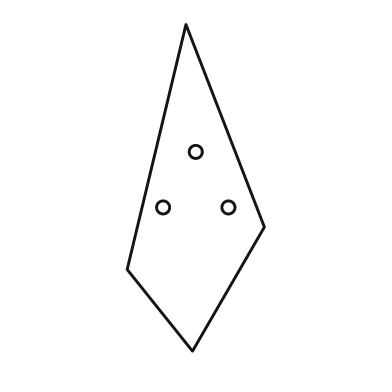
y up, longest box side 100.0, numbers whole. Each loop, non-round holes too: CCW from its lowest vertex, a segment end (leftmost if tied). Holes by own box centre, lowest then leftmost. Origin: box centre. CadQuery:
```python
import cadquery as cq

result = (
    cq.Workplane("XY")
    .moveTo(-1.0, -50.0)
    .lineTo(21.0, -12.0)
    .lineTo(-3.0, 50.0)
    .lineTo(-21.0, -25.0)
    .close()
    .moveTo(-10.0, -6.0)
    .circle(2.0)
    .moveTo(10.0, -6.0)
    .circle(2.0)
    .moveTo(0.0, 11.0)
    .circle(2.0)
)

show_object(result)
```